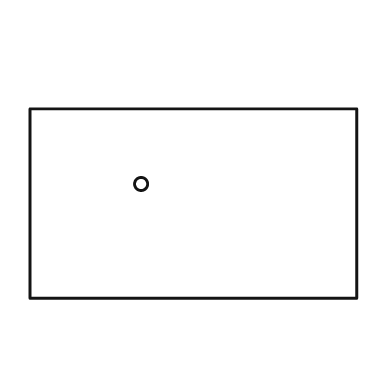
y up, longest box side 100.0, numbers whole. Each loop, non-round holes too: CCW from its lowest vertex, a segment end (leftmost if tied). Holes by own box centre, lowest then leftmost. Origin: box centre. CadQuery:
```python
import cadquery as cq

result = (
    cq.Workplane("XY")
    .moveTo(-50.0, -29.0)
    .lineTo(50.0, -29.0)
    .lineTo(50.0, 29.0)
    .lineTo(-50.0, 29.0)
    .close()
    .moveTo(-16.0, 6.0)
    .circle(2.0)
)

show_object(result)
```